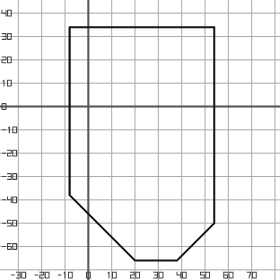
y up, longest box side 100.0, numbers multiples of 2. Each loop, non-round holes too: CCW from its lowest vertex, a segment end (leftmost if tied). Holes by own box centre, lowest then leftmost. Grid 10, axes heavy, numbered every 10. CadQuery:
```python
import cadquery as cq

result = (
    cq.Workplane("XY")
    .moveTo(20.0, -66.0)
    .lineTo(38.0, -66.0)
    .lineTo(54.0, -50.0)
    .lineTo(54.0, 34.0)
    .lineTo(-8.0, 34.0)
    .lineTo(-8.0, -38.0)
    .close()
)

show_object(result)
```